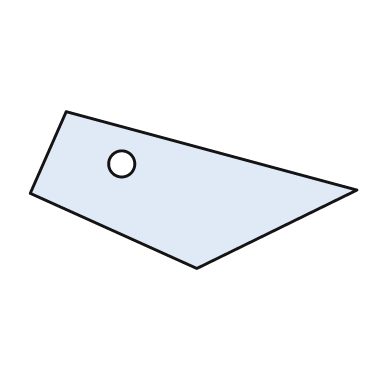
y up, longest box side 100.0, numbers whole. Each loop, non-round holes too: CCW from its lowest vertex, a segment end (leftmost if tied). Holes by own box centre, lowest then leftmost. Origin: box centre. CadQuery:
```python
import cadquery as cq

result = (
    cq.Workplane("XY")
    .moveTo(1.0, -24.0)
    .lineTo(50.0, 0.0)
    .lineTo(-39.0, 24.0)
    .lineTo(-50.0, -1.0)
    .close()
    .moveTo(-22.0, 8.0)
    .circle(4.0)
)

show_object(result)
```